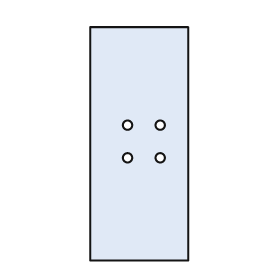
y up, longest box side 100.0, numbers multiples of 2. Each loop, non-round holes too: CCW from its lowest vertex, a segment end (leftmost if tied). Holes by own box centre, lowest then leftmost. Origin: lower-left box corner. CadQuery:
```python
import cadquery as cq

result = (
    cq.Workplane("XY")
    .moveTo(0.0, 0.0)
    .lineTo(42.0, 0.0)
    .lineTo(42.0, 100.0)
    .lineTo(0.0, 100.0)
    .close()
    .moveTo(16.0, 44.0)
    .circle(2.0)
    .moveTo(30.0, 44.0)
    .circle(2.0)
    .moveTo(16.0, 58.0)
    .circle(2.0)
    .moveTo(30.0, 58.0)
    .circle(2.0)
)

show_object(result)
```